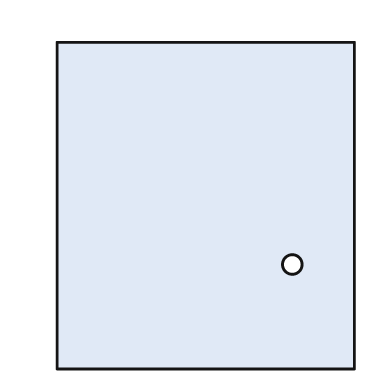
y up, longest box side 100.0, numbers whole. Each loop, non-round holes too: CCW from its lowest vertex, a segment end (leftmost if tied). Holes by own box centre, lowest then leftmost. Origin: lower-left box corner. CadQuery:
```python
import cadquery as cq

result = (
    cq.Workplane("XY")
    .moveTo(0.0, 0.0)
    .lineTo(91.0, 0.0)
    .lineTo(91.0, 100.0)
    .lineTo(0.0, 100.0)
    .close()
    .moveTo(72.0, 32.0)
    .circle(3.0)
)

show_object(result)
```